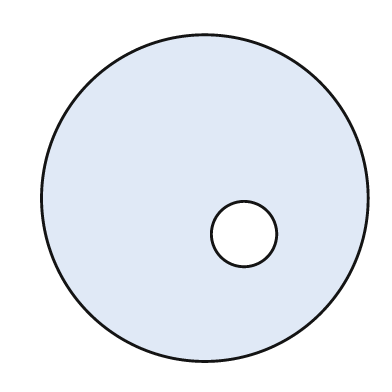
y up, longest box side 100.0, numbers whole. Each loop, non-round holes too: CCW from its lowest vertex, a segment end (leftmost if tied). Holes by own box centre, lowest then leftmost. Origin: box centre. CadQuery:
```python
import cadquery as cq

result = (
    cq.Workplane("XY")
    .moveTo(0.0, 0.0)
    .circle(50.0)
    .moveTo(12.0, -11.0)
    .circle(10.0)
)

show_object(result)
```